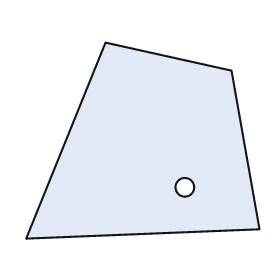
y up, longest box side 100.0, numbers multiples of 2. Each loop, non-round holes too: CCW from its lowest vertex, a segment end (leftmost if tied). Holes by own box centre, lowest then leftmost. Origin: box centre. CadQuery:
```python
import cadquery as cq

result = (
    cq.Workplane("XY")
    .moveTo(-50.0, -42.0)
    .lineTo(50.0, -38.0)
    .lineTo(38.0, 30.0)
    .lineTo(-16.0, 42.0)
    .close()
    .moveTo(18.0, -20.0)
    .circle(4.0)
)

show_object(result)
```